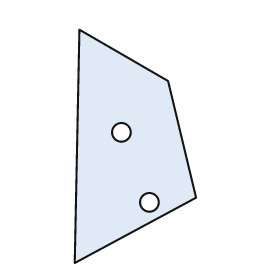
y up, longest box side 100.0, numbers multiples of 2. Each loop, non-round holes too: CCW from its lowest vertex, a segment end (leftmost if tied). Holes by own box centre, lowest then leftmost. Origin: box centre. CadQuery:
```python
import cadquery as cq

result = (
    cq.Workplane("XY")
    .moveTo(-26.0, -50.0)
    .lineTo(26.0, -22.0)
    .lineTo(14.0, 28.0)
    .lineTo(-24.0, 50.0)
    .close()
    .moveTo(6.0, -24.0)
    .circle(4.0)
    .moveTo(-6.0, 6.0)
    .circle(4.0)
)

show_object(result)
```